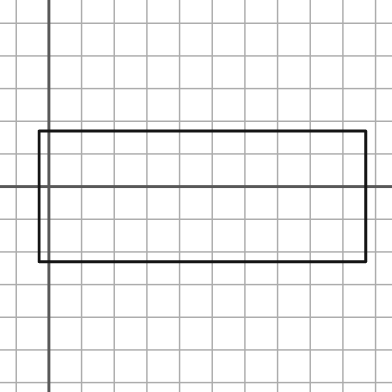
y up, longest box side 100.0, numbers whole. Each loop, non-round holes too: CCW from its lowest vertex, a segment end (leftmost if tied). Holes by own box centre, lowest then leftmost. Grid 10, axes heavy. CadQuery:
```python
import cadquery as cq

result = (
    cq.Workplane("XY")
    .moveTo(-3.0, -23.0)
    .lineTo(97.0, -23.0)
    .lineTo(97.0, 17.0)
    .lineTo(-3.0, 17.0)
    .close()
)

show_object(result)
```